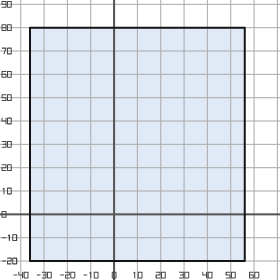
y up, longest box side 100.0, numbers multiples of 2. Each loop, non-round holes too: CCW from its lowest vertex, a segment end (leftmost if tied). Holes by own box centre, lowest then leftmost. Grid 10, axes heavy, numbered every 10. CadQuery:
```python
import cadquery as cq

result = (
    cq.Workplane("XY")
    .moveTo(-36.0, -20.0)
    .lineTo(56.0, -20.0)
    .lineTo(56.0, 80.0)
    .lineTo(-36.0, 80.0)
    .close()
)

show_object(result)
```